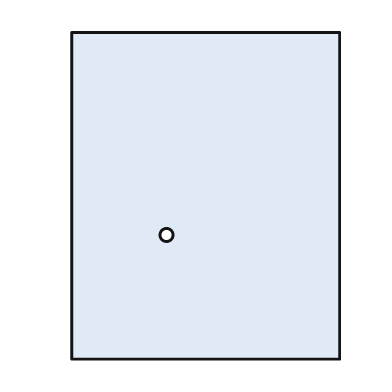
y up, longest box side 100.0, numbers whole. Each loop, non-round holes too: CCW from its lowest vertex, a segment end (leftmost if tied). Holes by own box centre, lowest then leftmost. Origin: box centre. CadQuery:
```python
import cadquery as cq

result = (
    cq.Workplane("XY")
    .moveTo(-41.0, -50.0)
    .lineTo(41.0, -50.0)
    .lineTo(41.0, 50.0)
    .lineTo(-41.0, 50.0)
    .close()
    .moveTo(-12.0, -12.0)
    .circle(2.0)
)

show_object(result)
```